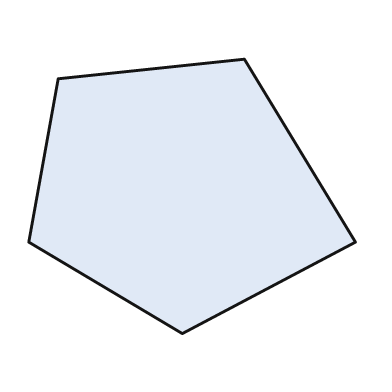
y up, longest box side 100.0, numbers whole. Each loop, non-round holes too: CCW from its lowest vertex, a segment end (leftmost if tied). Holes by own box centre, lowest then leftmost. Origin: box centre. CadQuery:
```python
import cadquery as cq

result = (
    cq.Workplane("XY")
    .moveTo(-3.0, -42.0)
    .lineTo(50.0, -14.0)
    .lineTo(16.0, 42.0)
    .lineTo(-41.0, 36.0)
    .lineTo(-50.0, -14.0)
    .close()
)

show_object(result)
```